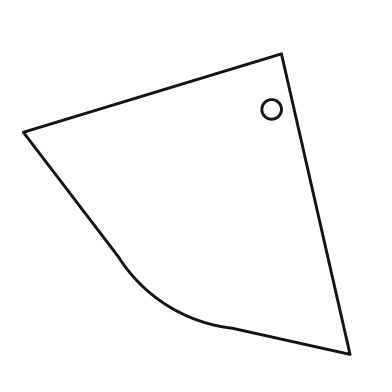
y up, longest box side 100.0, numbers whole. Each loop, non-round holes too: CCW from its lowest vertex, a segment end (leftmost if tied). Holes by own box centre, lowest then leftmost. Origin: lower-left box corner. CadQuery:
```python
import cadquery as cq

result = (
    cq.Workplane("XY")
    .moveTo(100.0, 0.0)
    .lineTo(79.0, 92.0)
    .lineTo(0.0, 68.0)
    .lineTo(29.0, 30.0)
    .threePointArc((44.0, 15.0), (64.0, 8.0))
    .close()
    .moveTo(76.0, 75.0)
    .circle(3.0)
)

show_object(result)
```